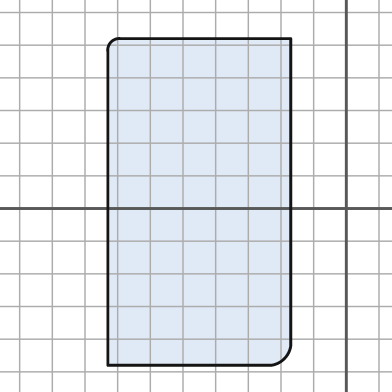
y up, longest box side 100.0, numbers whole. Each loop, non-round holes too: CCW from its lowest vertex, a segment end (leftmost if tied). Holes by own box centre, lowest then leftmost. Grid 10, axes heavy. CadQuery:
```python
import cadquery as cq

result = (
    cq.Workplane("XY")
    .moveTo(-73.0, -48.0)
    .lineTo(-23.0, -48.0)
    .threePointArc((-19.0, -46.0), (-17.0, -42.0))
    .lineTo(-17.0, 52.0)
    .lineTo(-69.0, 52.0)
    .threePointArc((-72.0, 51.0), (-73.0, 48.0))
    .close()
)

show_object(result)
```